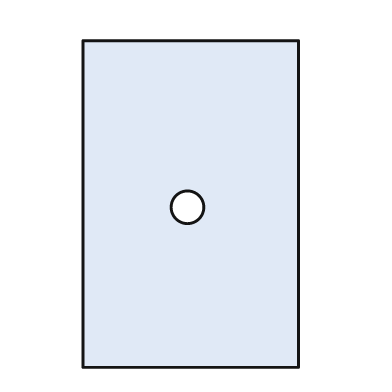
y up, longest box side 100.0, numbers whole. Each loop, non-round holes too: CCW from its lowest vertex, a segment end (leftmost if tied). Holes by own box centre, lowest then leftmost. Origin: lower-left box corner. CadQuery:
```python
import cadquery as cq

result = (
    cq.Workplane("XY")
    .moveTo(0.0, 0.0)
    .lineTo(66.0, 0.0)
    .lineTo(66.0, 100.0)
    .lineTo(0.0, 100.0)
    .close()
    .moveTo(32.0, 49.0)
    .circle(5.0)
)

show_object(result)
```